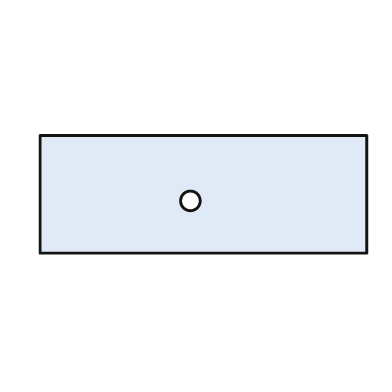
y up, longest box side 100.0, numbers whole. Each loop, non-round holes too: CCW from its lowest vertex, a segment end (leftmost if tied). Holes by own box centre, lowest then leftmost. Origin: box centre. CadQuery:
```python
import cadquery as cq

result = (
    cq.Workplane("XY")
    .moveTo(-50.0, -18.0)
    .lineTo(50.0, -18.0)
    .lineTo(50.0, 18.0)
    .lineTo(-50.0, 18.0)
    .close()
    .moveTo(-4.0, -2.0)
    .circle(3.0)
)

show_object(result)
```